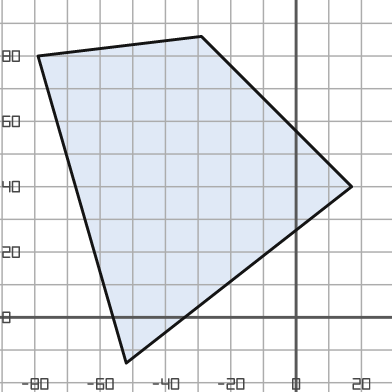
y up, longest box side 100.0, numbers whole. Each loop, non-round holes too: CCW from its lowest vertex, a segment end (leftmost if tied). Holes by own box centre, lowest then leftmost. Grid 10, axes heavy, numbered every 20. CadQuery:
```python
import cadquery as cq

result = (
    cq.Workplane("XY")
    .moveTo(-52.0, -14.0)
    .lineTo(17.0, 40.0)
    .lineTo(-29.0, 86.0)
    .lineTo(-79.0, 80.0)
    .close()
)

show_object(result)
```